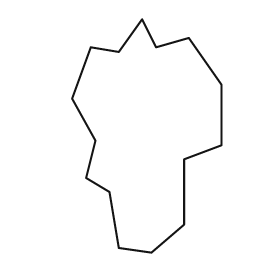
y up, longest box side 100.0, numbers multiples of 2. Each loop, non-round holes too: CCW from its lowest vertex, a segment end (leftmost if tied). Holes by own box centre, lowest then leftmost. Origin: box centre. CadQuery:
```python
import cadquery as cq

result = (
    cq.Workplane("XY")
    .moveTo(2.0, -50.0)
    .lineTo(16.0, -38.0)
    .lineTo(16.0, -10.0)
    .lineTo(32.0, -4.0)
    .lineTo(32.0, 22.0)
    .lineTo(18.0, 42.0)
    .lineTo(4.0, 38.0)
    .lineTo(-2.0, 50.0)
    .lineTo(-12.0, 36.0)
    .lineTo(-24.0, 38.0)
    .lineTo(-32.0, 16.0)
    .lineTo(-22.0, -2.0)
    .lineTo(-26.0, -18.0)
    .lineTo(-16.0, -24.0)
    .lineTo(-12.0, -48.0)
    .close()
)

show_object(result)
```